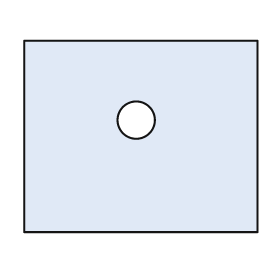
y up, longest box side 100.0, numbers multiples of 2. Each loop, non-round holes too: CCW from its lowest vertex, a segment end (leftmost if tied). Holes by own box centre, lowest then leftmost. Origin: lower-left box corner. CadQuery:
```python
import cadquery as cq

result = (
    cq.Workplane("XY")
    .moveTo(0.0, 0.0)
    .lineTo(100.0, 0.0)
    .lineTo(100.0, 82.0)
    .lineTo(0.0, 82.0)
    .close()
    .moveTo(48.0, 48.0)
    .circle(8.0)
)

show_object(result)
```